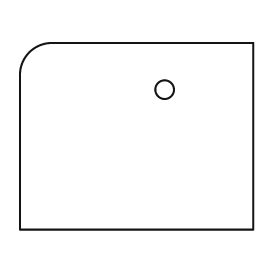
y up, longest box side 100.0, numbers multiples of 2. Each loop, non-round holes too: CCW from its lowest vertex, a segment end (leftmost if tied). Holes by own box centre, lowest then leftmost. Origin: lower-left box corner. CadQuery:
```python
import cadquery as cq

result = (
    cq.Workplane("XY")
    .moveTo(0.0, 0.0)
    .lineTo(100.0, 0.0)
    .lineTo(100.0, 80.0)
    .lineTo(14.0, 80.0)
    .threePointArc((4.0, 76.0), (0.0, 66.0))
    .close()
    .moveTo(62.0, 60.0)
    .circle(4.0)
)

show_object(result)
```